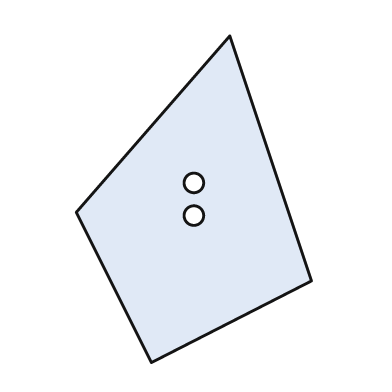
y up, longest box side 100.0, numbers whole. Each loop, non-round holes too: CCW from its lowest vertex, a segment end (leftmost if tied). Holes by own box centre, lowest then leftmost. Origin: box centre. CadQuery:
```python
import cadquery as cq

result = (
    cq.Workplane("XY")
    .moveTo(-13.0, -50.0)
    .lineTo(36.0, -25.0)
    .lineTo(11.0, 50.0)
    .lineTo(-36.0, -4.0)
    .close()
    .moveTo(0.0, -5.0)
    .circle(3.0)
    .moveTo(0.0, 5.0)
    .circle(3.0)
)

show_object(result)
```